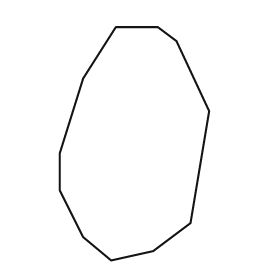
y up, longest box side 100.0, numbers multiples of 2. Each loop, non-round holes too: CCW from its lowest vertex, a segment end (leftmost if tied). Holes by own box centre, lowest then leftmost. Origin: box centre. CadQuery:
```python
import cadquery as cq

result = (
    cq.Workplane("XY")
    .moveTo(-10.0, -50.0)
    .lineTo(8.0, -46.0)
    .lineTo(24.0, -34.0)
    .lineTo(32.0, 14.0)
    .lineTo(18.0, 44.0)
    .lineTo(10.0, 50.0)
    .lineTo(-8.0, 50.0)
    .lineTo(-22.0, 28.0)
    .lineTo(-32.0, -4.0)
    .lineTo(-32.0, -20.0)
    .lineTo(-22.0, -40.0)
    .close()
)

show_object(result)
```